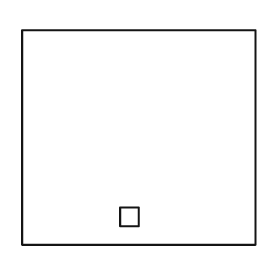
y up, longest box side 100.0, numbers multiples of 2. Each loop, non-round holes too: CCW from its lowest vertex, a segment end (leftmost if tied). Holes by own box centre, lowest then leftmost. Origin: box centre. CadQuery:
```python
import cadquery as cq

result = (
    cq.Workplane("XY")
    .moveTo(-50.0, -46.0)
    .lineTo(50.0, -46.0)
    .lineTo(50.0, 46.0)
    .lineTo(-50.0, 46.0)
    .close()
    .moveTo(-8.0, -38.0)
    .lineTo(0.0, -38.0)
    .lineTo(0.0, -30.0)
    .lineTo(-8.0, -30.0)
    .close()
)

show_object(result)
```